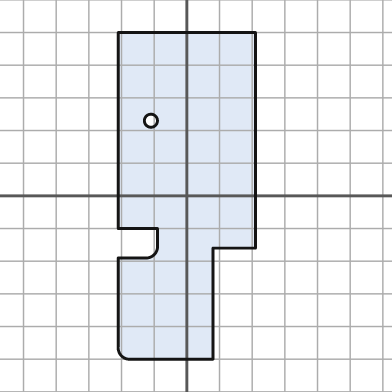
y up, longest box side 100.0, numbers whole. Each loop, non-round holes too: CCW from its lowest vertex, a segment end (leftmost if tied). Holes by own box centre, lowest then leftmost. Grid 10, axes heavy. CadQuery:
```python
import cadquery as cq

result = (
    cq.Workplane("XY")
    .moveTo(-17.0, -50.0)
    .lineTo(8.0, -50.0)
    .lineTo(8.0, -16.0)
    .lineTo(21.0, -16.0)
    .lineTo(21.0, 50.0)
    .lineTo(-21.0, 50.0)
    .lineTo(-21.0, -10.0)
    .lineTo(-9.0, -10.0)
    .lineTo(-9.0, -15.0)
    .threePointArc((-10.0, -18.0), (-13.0, -19.0))
    .lineTo(-21.0, -19.0)
    .lineTo(-21.0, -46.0)
    .threePointArc((-20.0, -49.0), (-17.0, -50.0))
    .close()
    .moveTo(-11.0, 23.0)
    .circle(2.0)
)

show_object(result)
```